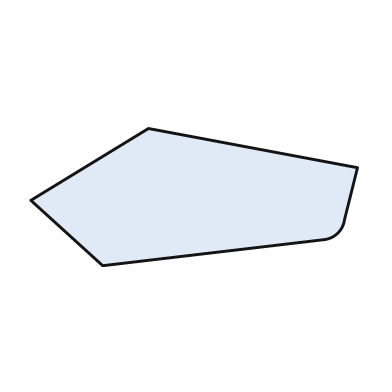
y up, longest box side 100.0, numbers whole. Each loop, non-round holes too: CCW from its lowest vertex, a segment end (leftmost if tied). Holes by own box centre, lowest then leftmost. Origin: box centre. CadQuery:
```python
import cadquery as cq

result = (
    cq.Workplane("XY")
    .moveTo(-28.0, -21.0)
    .lineTo(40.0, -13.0)
    .threePointArc((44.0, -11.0), (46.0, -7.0))
    .lineTo(50.0, 9.0)
    .lineTo(-14.0, 21.0)
    .lineTo(-50.0, -1.0)
    .close()
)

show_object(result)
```